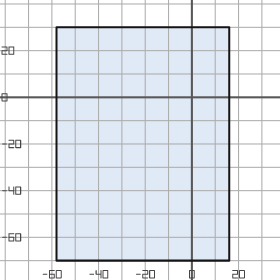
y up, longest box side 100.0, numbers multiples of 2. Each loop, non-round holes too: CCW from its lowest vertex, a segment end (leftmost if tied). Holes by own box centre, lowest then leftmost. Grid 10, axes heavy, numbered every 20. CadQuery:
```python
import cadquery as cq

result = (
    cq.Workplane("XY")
    .moveTo(-58.0, -70.0)
    .lineTo(16.0, -70.0)
    .lineTo(16.0, 30.0)
    .lineTo(-58.0, 30.0)
    .close()
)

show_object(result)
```